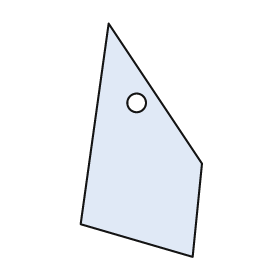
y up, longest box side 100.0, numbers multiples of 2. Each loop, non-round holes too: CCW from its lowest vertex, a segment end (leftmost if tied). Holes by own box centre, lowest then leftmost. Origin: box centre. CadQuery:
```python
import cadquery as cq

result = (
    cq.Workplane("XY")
    .moveTo(22.0, -50.0)
    .lineTo(26.0, -10.0)
    .lineTo(-14.0, 50.0)
    .lineTo(-26.0, -36.0)
    .close()
    .moveTo(-2.0, 16.0)
    .circle(4.0)
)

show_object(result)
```